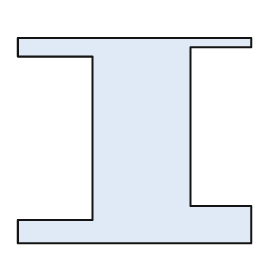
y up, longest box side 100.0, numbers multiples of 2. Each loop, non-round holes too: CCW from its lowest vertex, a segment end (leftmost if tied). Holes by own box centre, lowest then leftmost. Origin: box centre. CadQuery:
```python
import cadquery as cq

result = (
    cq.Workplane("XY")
    .moveTo(-50.0, -44.0)
    .lineTo(50.0, -44.0)
    .lineTo(50.0, -28.0)
    .lineTo(24.0, -28.0)
    .lineTo(24.0, 40.0)
    .lineTo(50.0, 40.0)
    .lineTo(50.0, 44.0)
    .lineTo(-50.0, 44.0)
    .lineTo(-50.0, 36.0)
    .lineTo(-18.0, 36.0)
    .lineTo(-18.0, -34.0)
    .lineTo(-50.0, -34.0)
    .close()
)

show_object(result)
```